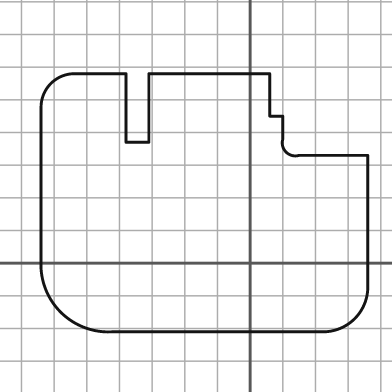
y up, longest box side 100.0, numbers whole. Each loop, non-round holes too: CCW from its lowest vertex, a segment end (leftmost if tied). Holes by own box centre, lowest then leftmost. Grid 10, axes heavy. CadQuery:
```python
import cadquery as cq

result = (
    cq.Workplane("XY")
    .moveTo(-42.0, -21.0)
    .lineTo(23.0, -21.0)
    .threePointArc((32.0, -17.0), (36.0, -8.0))
    .lineTo(36.0, 33.0)
    .lineTo(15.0, 33.0)
    .threePointArc((11.0, 34.0), (10.0, 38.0))
    .lineTo(10.0, 45.0)
    .lineTo(6.0, 45.0)
    .lineTo(6.0, 58.0)
    .lineTo(-31.0, 58.0)
    .lineTo(-31.0, 37.0)
    .lineTo(-38.0, 37.0)
    .lineTo(-38.0, 58.0)
    .lineTo(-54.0, 58.0)
    .threePointArc((-61.0, 55.0), (-64.0, 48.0))
    .lineTo(-64.0, 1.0)
    .threePointArc((-58.0, -15.0), (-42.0, -21.0))
    .close()
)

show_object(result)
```